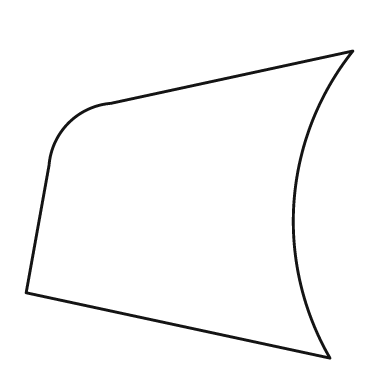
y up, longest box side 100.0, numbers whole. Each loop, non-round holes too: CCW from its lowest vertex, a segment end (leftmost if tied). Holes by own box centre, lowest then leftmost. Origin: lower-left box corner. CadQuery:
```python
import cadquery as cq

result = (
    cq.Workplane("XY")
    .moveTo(93.0, 0.0)
    .threePointArc((82.0, 48.0), (100.0, 94.0))
    .lineTo(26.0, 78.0)
    .threePointArc((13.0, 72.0), (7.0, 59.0))
    .lineTo(0.0, 20.0)
    .close()
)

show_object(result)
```